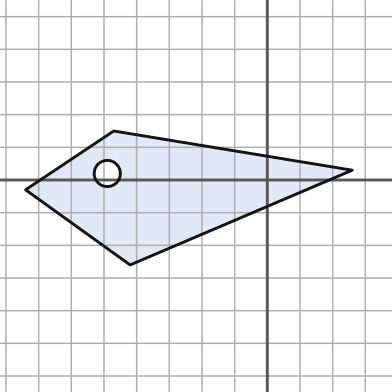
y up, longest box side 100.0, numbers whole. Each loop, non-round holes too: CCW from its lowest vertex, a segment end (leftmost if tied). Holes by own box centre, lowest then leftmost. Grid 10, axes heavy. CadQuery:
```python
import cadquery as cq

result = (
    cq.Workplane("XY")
    .moveTo(-42.0, -26.0)
    .lineTo(26.0, 3.0)
    .lineTo(-47.0, 15.0)
    .lineTo(-74.0, -3.0)
    .close()
    .moveTo(-49.0, 2.0)
    .circle(4.0)
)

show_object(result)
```